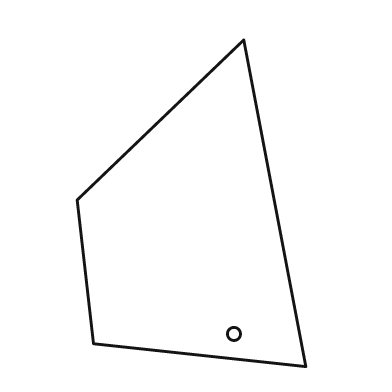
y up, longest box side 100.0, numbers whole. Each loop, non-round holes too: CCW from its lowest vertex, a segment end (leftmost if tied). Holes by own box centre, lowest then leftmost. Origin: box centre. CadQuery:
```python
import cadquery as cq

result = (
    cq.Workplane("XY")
    .moveTo(35.0, -50.0)
    .lineTo(16.0, 50.0)
    .lineTo(-35.0, 1.0)
    .lineTo(-30.0, -43.0)
    .close()
    .moveTo(13.0, -40.0)
    .circle(2.0)
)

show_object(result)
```